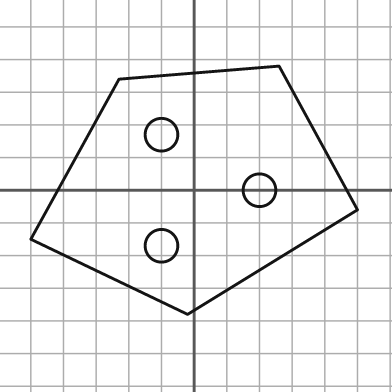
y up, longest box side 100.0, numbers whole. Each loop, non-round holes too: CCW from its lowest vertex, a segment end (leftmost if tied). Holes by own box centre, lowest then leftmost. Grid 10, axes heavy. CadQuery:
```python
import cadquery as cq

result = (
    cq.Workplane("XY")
    .moveTo(-2.0, -38.0)
    .lineTo(50.0, -6.0)
    .lineTo(26.0, 38.0)
    .lineTo(-23.0, 34.0)
    .lineTo(-50.0, -15.0)
    .close()
    .moveTo(-10.0, -17.0)
    .circle(5.0)
    .moveTo(20.0, 0.0)
    .circle(5.0)
    .moveTo(-10.0, 17.0)
    .circle(5.0)
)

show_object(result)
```